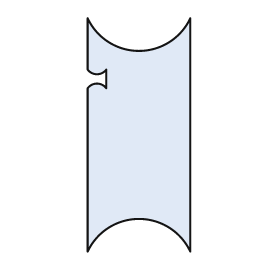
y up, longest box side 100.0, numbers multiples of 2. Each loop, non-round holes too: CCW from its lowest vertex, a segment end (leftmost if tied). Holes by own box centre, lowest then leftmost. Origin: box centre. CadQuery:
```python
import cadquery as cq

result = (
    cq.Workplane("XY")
    .moveTo(-22.0, -50.0)
    .threePointArc((0.0, -36.0), (22.0, -50.0))
    .lineTo(22.0, 50.0)
    .threePointArc((0.0, 36.0), (-22.0, 50.0))
    .lineTo(-22.0, 28.0)
    .threePointArc((-18.0, 26.0), (-14.0, 28.0))
    .lineTo(-14.0, 20.0)
    .threePointArc((-18.0, 22.0), (-22.0, 20.0))
    .close()
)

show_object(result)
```